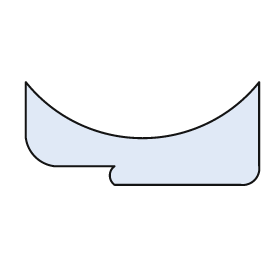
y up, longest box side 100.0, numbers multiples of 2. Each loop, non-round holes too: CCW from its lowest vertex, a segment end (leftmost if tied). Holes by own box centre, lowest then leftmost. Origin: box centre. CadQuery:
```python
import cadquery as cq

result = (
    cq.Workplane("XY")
    .moveTo(-12.0, -22.0)
    .lineTo(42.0, -22.0)
    .threePointArc((48.0, -20.0), (50.0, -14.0))
    .lineTo(50.0, 22.0)
    .threePointArc((0.0, -2.0), (-50.0, 22.0))
    .lineTo(-50.0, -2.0)
    .threePointArc((-46.0, -10.0), (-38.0, -14.0))
    .lineTo(-12.0, -14.0)
    .threePointArc((-14.0, -18.0), (-12.0, -22.0))
    .close()
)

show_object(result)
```